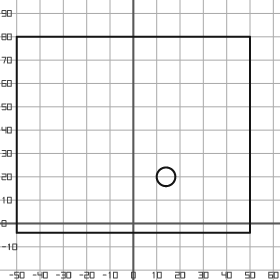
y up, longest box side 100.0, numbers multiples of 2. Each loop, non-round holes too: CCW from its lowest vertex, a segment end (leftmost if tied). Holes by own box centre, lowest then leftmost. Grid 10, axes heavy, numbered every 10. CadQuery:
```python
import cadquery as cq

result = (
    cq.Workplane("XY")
    .moveTo(-50.0, -4.0)
    .lineTo(50.0, -4.0)
    .lineTo(50.0, 80.0)
    .lineTo(-50.0, 80.0)
    .close()
    .moveTo(14.0, 20.0)
    .circle(4.0)
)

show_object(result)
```